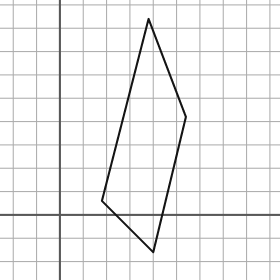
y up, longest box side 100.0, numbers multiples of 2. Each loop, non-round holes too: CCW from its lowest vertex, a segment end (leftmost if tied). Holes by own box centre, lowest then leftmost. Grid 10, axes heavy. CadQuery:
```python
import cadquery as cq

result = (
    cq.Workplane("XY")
    .moveTo(40.0, -16.0)
    .lineTo(54.0, 42.0)
    .lineTo(38.0, 84.0)
    .lineTo(18.0, 6.0)
    .close()
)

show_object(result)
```